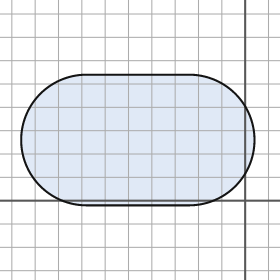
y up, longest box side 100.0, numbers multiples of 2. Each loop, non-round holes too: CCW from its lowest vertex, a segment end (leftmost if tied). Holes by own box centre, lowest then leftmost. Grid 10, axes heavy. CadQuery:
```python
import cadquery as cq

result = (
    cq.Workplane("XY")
    .moveTo(-68.0, -2.0)
    .lineTo(-24.0, -2.0)
    .threePointArc((4.0, 26.0), (-24.0, 54.0))
    .lineTo(-68.0, 54.0)
    .threePointArc((-96.0, 26.0), (-68.0, -2.0))
    .close()
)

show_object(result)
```